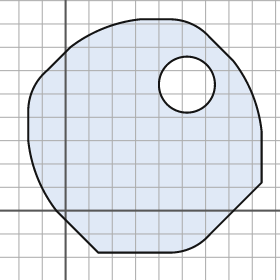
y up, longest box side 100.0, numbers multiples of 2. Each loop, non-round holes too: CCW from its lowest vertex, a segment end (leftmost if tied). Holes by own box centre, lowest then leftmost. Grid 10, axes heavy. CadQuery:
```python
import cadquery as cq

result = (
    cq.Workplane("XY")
    .moveTo(14.0, -18.0)
    .lineTo(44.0, -18.0)
    .threePointArc((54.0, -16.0), (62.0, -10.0))
    .lineTo(84.0, 12.0)
    .lineTo(84.0, 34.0)
    .threePointArc((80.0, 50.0), (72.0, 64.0))
    .lineTo(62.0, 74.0)
    .threePointArc((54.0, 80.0), (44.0, 82.0))
    .lineTo(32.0, 82.0)
    .threePointArc((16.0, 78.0), (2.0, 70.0))
    .lineTo(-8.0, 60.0)
    .threePointArc((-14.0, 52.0), (-16.0, 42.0))
    .lineTo(-16.0, 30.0)
    .threePointArc((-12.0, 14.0), (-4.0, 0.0))
    .close()
    .moveTo(52.0, 54.0)
    .circle(12.0)
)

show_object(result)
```